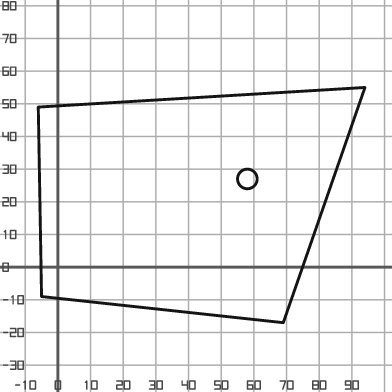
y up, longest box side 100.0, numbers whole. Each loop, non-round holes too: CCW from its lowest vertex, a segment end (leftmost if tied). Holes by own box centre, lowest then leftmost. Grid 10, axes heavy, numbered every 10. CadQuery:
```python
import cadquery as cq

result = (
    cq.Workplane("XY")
    .moveTo(69.0, -17.0)
    .lineTo(94.0, 55.0)
    .lineTo(-6.0, 49.0)
    .lineTo(-5.0, -9.0)
    .close()
    .moveTo(58.0, 27.0)
    .circle(3.0)
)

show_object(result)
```